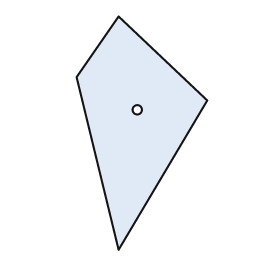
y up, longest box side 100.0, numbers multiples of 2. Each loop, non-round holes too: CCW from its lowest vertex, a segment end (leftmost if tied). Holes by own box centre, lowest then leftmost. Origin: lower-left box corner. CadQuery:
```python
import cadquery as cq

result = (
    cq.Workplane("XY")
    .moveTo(18.0, 0.0)
    .lineTo(56.0, 64.0)
    .lineTo(18.0, 100.0)
    .lineTo(0.0, 74.0)
    .close()
    .moveTo(26.0, 60.0)
    .circle(2.0)
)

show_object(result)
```